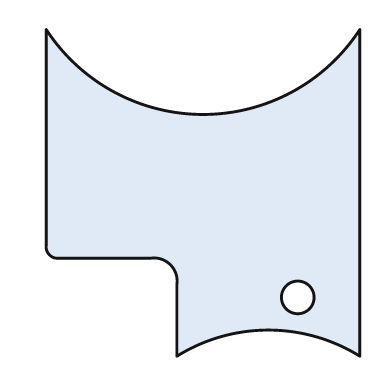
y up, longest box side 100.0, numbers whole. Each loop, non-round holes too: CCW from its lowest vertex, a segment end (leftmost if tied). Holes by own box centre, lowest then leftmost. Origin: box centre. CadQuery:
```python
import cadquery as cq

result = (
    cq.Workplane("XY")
    .moveTo(-8.0, -50.0)
    .threePointArc((20.0, -42.0), (48.0, -50.0))
    .lineTo(48.0, 50.0)
    .threePointArc((0.0, 24.0), (-48.0, 50.0))
    .lineTo(-48.0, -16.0)
    .threePointArc((-47.0, -19.0), (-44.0, -20.0))
    .lineTo(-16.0, -20.0)
    .threePointArc((-10.0, -22.0), (-8.0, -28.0))
    .close()
    .moveTo(29.0, -32.0)
    .circle(5.0)
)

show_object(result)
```